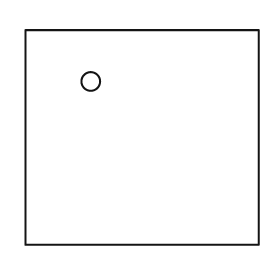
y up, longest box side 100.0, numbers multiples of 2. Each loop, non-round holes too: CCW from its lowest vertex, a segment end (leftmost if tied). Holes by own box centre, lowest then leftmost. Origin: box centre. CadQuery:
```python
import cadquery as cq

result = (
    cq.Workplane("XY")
    .moveTo(-50.0, -46.0)
    .lineTo(50.0, -46.0)
    .lineTo(50.0, 46.0)
    .lineTo(-50.0, 46.0)
    .close()
    .moveTo(-22.0, 24.0)
    .circle(4.0)
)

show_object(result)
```